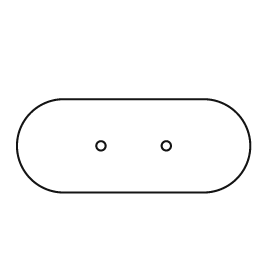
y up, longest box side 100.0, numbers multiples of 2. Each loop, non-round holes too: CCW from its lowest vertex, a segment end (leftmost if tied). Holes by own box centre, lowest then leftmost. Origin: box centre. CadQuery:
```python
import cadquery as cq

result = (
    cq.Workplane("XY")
    .moveTo(-30.0, -20.0)
    .lineTo(30.0, -20.0)
    .threePointArc((50.0, 0.0), (30.0, 20.0))
    .lineTo(-30.0, 20.0)
    .threePointArc((-50.0, 0.0), (-30.0, -20.0))
    .close()
    .moveTo(-14.0, 0.0)
    .circle(2.0)
    .moveTo(14.0, 0.0)
    .circle(2.0)
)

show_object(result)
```